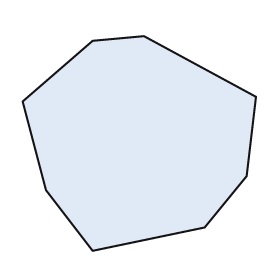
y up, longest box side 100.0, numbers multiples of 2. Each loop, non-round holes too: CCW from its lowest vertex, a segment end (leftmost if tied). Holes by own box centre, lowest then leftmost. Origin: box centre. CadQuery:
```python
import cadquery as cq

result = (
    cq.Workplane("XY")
    .moveTo(-20.0, -46.0)
    .lineTo(28.0, -36.0)
    .lineTo(46.0, -14.0)
    .lineTo(50.0, 20.0)
    .lineTo(2.0, 46.0)
    .lineTo(-20.0, 44.0)
    .lineTo(-50.0, 18.0)
    .lineTo(-40.0, -20.0)
    .close()
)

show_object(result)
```